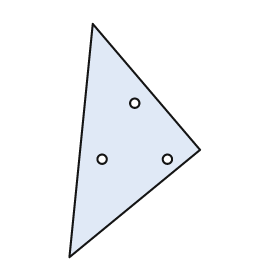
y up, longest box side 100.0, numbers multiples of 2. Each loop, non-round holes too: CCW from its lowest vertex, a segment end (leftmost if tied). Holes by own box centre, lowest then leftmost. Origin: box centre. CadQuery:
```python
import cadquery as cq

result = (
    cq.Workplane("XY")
    .moveTo(-28.0, -50.0)
    .lineTo(28.0, -4.0)
    .lineTo(-18.0, 50.0)
    .close()
    .moveTo(-14.0, -8.0)
    .circle(2.0)
    .moveTo(14.0, -8.0)
    .circle(2.0)
    .moveTo(0.0, 16.0)
    .circle(2.0)
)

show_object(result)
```